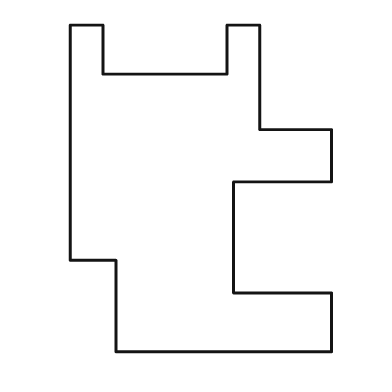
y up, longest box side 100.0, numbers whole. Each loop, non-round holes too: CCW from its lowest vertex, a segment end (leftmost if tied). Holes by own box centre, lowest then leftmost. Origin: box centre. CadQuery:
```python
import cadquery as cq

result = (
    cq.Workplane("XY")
    .moveTo(-26.0, -50.0)
    .lineTo(40.0, -50.0)
    .lineTo(40.0, -32.0)
    .lineTo(10.0, -32.0)
    .lineTo(10.0, 2.0)
    .lineTo(40.0, 2.0)
    .lineTo(40.0, 18.0)
    .lineTo(18.0, 18.0)
    .lineTo(18.0, 50.0)
    .lineTo(8.0, 50.0)
    .lineTo(8.0, 35.0)
    .lineTo(-30.0, 35.0)
    .lineTo(-30.0, 50.0)
    .lineTo(-40.0, 50.0)
    .lineTo(-40.0, -22.0)
    .lineTo(-26.0, -22.0)
    .close()
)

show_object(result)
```